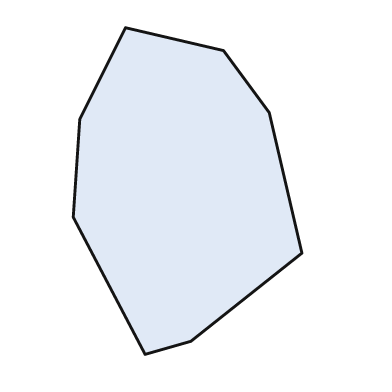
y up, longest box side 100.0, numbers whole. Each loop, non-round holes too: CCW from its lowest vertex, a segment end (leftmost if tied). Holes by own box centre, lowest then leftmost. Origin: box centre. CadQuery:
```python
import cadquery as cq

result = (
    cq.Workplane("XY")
    .moveTo(-13.0, -50.0)
    .lineTo(1.0, -46.0)
    .lineTo(35.0, -19.0)
    .lineTo(25.0, 24.0)
    .lineTo(11.0, 43.0)
    .lineTo(-19.0, 50.0)
    .lineTo(-33.0, 22.0)
    .lineTo(-35.0, -8.0)
    .close()
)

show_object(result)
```